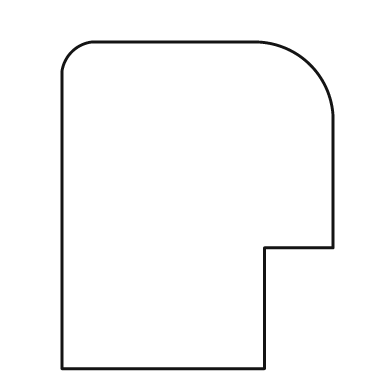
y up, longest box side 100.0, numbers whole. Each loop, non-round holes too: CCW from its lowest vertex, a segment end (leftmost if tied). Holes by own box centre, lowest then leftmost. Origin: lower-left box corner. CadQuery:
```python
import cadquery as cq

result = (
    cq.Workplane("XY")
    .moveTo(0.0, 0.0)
    .lineTo(62.0, 0.0)
    .lineTo(62.0, 37.0)
    .lineTo(83.0, 37.0)
    .lineTo(83.0, 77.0)
    .threePointArc((76.0, 93.0), (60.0, 100.0))
    .lineTo(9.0, 100.0)
    .threePointArc((3.0, 97.0), (0.0, 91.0))
    .close()
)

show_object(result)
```